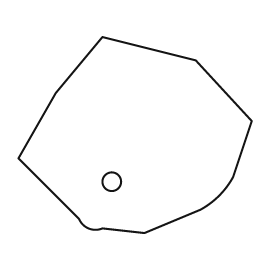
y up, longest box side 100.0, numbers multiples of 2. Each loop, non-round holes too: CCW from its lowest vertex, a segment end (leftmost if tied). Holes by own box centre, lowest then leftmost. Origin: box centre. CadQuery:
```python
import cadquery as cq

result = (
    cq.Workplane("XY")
    .moveTo(4.0, -42.0)
    .lineTo(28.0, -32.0)
    .threePointArc((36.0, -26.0), (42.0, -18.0))
    .lineTo(50.0, 6.0)
    .lineTo(26.0, 32.0)
    .lineTo(-14.0, 42.0)
    .lineTo(-34.0, 18.0)
    .lineTo(-50.0, -10.0)
    .lineTo(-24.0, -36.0)
    .threePointArc((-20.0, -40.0), (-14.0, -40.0))
    .close()
    .moveTo(-10.0, -20.0)
    .circle(4.0)
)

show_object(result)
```